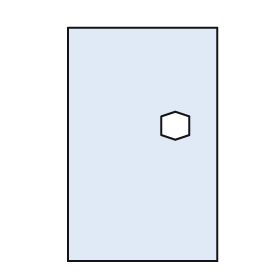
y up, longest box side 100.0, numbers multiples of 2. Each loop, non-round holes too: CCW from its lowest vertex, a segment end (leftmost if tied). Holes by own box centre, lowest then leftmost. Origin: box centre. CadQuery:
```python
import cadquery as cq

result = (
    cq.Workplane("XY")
    .moveTo(-32.0, -50.0)
    .lineTo(32.0, -50.0)
    .lineTo(32.0, 50.0)
    .lineTo(-32.0, 50.0)
    .close()
    .moveTo(14.0, 2.0)
    .lineTo(20.0, 4.0)
    .lineTo(20.0, 12.0)
    .lineTo(14.0, 14.0)
    .lineTo(8.0, 12.0)
    .lineTo(8.0, 4.0)
    .close()
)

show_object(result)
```